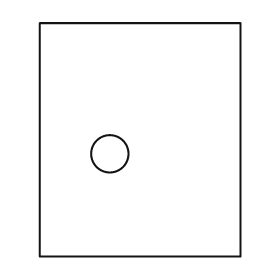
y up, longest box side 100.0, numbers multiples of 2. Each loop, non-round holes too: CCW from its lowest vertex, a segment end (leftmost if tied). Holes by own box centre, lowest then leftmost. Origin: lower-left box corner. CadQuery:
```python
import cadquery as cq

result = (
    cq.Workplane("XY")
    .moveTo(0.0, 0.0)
    .lineTo(86.0, 0.0)
    .lineTo(86.0, 100.0)
    .lineTo(0.0, 100.0)
    .close()
    .moveTo(30.0, 44.0)
    .circle(8.0)
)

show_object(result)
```